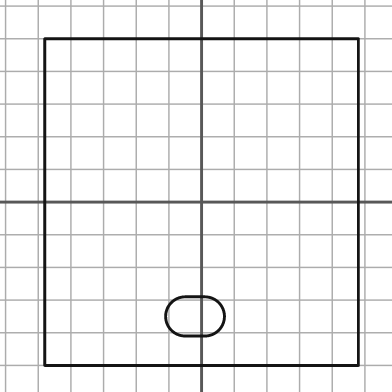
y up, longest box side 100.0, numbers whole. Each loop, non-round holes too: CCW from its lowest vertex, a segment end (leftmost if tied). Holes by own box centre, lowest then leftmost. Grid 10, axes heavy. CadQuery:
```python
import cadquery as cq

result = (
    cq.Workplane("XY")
    .moveTo(-48.0, -50.0)
    .lineTo(48.0, -50.0)
    .lineTo(48.0, 50.0)
    .lineTo(-48.0, 50.0)
    .close()
    .moveTo(-5.0, -41.0)
    .lineTo(1.0, -41.0)
    .threePointArc((7.0, -35.0), (1.0, -29.0))
    .lineTo(-5.0, -29.0)
    .threePointArc((-11.0, -35.0), (-5.0, -41.0))
    .close()
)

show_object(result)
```